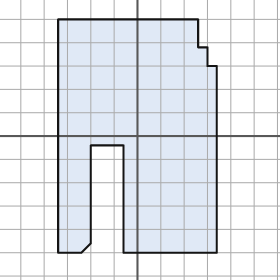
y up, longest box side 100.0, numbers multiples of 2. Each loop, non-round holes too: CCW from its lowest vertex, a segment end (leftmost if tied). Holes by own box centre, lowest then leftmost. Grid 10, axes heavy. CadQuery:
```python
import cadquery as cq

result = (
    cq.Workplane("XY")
    .moveTo(-34.0, -50.0)
    .lineTo(-24.0, -50.0)
    .lineTo(-20.0, -46.0)
    .lineTo(-20.0, -4.0)
    .lineTo(-6.0, -4.0)
    .lineTo(-6.0, -50.0)
    .lineTo(34.0, -50.0)
    .lineTo(34.0, 30.0)
    .lineTo(30.0, 30.0)
    .lineTo(30.0, 38.0)
    .lineTo(26.0, 38.0)
    .lineTo(26.0, 50.0)
    .lineTo(-34.0, 50.0)
    .close()
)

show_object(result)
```